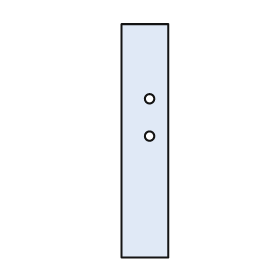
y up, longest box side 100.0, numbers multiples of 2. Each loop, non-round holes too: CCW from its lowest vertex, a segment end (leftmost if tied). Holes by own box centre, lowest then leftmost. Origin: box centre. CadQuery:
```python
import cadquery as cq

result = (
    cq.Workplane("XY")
    .moveTo(-10.0, -50.0)
    .lineTo(10.0, -50.0)
    .lineTo(10.0, 50.0)
    .lineTo(-10.0, 50.0)
    .close()
    .moveTo(2.0, 2.0)
    .circle(2.0)
    .moveTo(2.0, 18.0)
    .circle(2.0)
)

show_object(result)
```